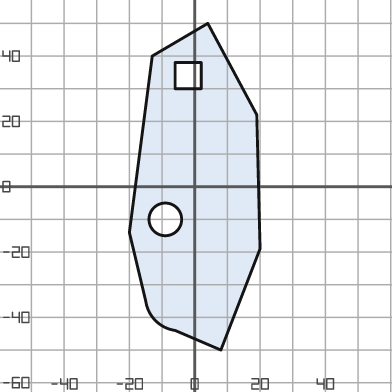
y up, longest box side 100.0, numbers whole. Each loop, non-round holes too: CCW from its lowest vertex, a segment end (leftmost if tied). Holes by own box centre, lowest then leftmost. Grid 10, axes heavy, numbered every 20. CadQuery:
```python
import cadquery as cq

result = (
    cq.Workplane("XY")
    .moveTo(8.0, -50.0)
    .lineTo(20.0, -19.0)
    .lineTo(19.0, 22.0)
    .lineTo(4.0, 50.0)
    .lineTo(-13.0, 40.0)
    .lineTo(-20.0, -14.0)
    .lineTo(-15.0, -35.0)
    .threePointArc((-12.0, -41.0), (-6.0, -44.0))
    .close()
    .moveTo(-9.0, -10.0)
    .circle(5.0)
    .moveTo(-6.0, 30.0)
    .lineTo(2.0, 30.0)
    .lineTo(2.0, 38.0)
    .lineTo(-6.0, 38.0)
    .close()
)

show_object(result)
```